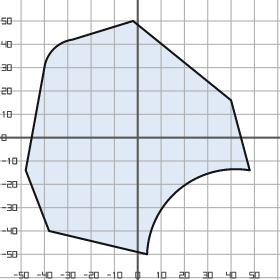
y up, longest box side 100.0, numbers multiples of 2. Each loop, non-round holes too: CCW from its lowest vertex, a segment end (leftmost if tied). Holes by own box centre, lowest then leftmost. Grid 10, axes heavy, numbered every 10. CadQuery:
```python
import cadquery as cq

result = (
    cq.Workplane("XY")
    .moveTo(4.0, -50.0)
    .threePointArc((18.0, -22.0), (48.0, -14.0))
    .lineTo(40.0, 16.0)
    .lineTo(-2.0, 50.0)
    .lineTo(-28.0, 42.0)
    .threePointArc((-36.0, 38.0), (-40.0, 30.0))
    .lineTo(-48.0, -14.0)
    .lineTo(-38.0, -40.0)
    .close()
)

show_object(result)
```